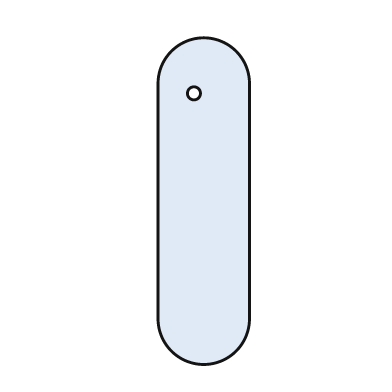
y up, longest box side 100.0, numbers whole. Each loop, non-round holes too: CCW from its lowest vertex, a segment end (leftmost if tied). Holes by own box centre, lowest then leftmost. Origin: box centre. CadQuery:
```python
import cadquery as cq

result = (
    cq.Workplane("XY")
    .moveTo(-14.0, -36.0)
    .threePointArc((0.0, -50.0), (14.0, -36.0))
    .lineTo(14.0, 36.0)
    .threePointArc((0.0, 50.0), (-14.0, 36.0))
    .close()
    .moveTo(-3.0, 33.0)
    .circle(2.0)
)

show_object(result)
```